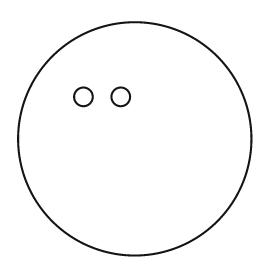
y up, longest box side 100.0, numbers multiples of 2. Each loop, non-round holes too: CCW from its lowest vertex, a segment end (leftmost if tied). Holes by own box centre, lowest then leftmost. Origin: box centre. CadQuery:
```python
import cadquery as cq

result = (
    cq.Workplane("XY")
    .moveTo(0.0, 0.0)
    .circle(50.0)
    .moveTo(-22.0, 18.0)
    .circle(4.0)
    .moveTo(-6.0, 18.0)
    .circle(4.0)
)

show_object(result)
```